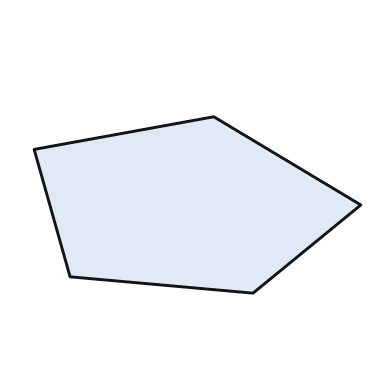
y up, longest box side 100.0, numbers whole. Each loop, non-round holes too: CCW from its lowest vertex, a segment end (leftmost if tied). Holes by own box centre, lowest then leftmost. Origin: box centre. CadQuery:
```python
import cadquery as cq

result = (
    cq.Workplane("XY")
    .moveTo(17.0, -27.0)
    .lineTo(50.0, 0.0)
    .lineTo(5.0, 27.0)
    .lineTo(-50.0, 17.0)
    .lineTo(-39.0, -22.0)
    .close()
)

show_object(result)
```